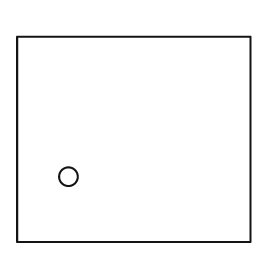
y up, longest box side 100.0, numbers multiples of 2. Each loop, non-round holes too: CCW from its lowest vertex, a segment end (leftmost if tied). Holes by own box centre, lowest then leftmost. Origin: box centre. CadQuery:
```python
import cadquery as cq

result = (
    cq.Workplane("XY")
    .moveTo(-50.0, -44.0)
    .lineTo(50.0, -44.0)
    .lineTo(50.0, 44.0)
    .lineTo(-50.0, 44.0)
    .close()
    .moveTo(-28.0, -16.0)
    .circle(4.0)
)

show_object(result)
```